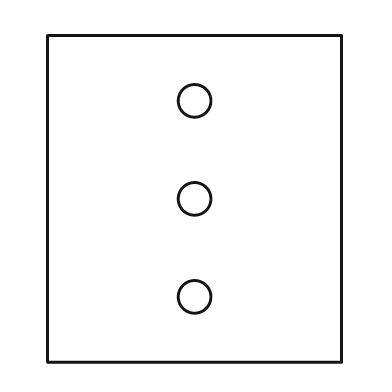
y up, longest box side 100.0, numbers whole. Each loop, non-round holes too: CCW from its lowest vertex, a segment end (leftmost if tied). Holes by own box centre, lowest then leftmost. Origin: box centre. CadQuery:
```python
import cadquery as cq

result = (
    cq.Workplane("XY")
    .moveTo(-45.0, -50.0)
    .lineTo(45.0, -50.0)
    .lineTo(45.0, 50.0)
    .lineTo(-45.0, 50.0)
    .close()
    .moveTo(0.0, -30.0)
    .circle(5.0)
    .moveTo(0.0, 0.0)
    .circle(5.0)
    .moveTo(0.0, 30.0)
    .circle(5.0)
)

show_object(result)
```